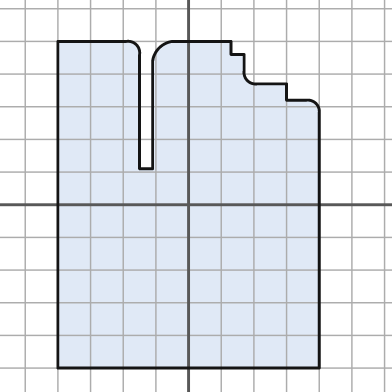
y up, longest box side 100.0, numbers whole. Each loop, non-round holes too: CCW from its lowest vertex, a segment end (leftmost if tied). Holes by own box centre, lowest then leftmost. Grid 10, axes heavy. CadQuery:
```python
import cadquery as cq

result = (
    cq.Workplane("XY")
    .moveTo(-40.0, -50.0)
    .lineTo(40.0, -50.0)
    .lineTo(40.0, 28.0)
    .threePointArc((39.0, 31.0), (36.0, 32.0))
    .lineTo(30.0, 32.0)
    .lineTo(30.0, 37.0)
    .lineTo(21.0, 37.0)
    .threePointArc((18.0, 38.0), (17.0, 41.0))
    .lineTo(17.0, 46.0)
    .lineTo(13.0, 46.0)
    .lineTo(13.0, 50.0)
    .lineTo(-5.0, 50.0)
    .threePointArc((-9.0, 48.0), (-11.0, 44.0))
    .lineTo(-11.0, 11.0)
    .lineTo(-15.0, 11.0)
    .lineTo(-15.0, 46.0)
    .threePointArc((-16.0, 49.0), (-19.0, 50.0))
    .lineTo(-40.0, 50.0)
    .close()
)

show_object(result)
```